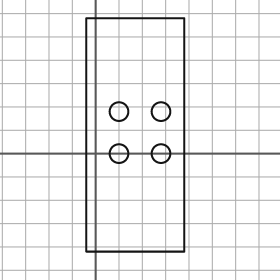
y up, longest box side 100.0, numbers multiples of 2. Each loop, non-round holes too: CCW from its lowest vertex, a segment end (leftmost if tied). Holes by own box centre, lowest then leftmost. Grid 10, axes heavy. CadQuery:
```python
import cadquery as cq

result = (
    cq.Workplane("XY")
    .moveTo(-4.0, -42.0)
    .lineTo(38.0, -42.0)
    .lineTo(38.0, 58.0)
    .lineTo(-4.0, 58.0)
    .close()
    .moveTo(10.0, 0.0)
    .circle(4.0)
    .moveTo(28.0, 0.0)
    .circle(4.0)
    .moveTo(10.0, 18.0)
    .circle(4.0)
    .moveTo(28.0, 18.0)
    .circle(4.0)
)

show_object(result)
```